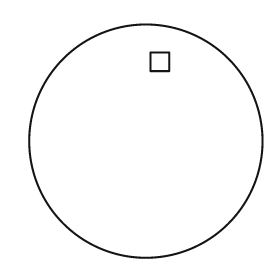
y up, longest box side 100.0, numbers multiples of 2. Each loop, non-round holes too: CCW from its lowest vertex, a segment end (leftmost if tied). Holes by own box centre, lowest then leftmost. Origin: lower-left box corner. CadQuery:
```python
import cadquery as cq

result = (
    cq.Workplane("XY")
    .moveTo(50.0, 50.0)
    .circle(50.0)
    .moveTo(52.0, 80.0)
    .lineTo(60.0, 80.0)
    .lineTo(60.0, 88.0)
    .lineTo(52.0, 88.0)
    .close()
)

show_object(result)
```